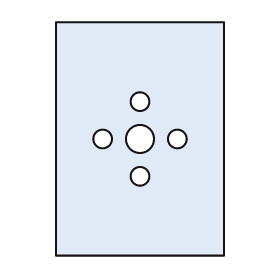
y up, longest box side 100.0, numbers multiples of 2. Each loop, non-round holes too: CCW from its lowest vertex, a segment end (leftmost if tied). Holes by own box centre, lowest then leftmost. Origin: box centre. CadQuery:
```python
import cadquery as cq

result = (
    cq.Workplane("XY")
    .moveTo(-36.0, -50.0)
    .lineTo(36.0, -50.0)
    .lineTo(36.0, 50.0)
    .lineTo(-36.0, 50.0)
    .close()
    .moveTo(0.0, -16.0)
    .circle(4.0)
    .moveTo(-16.0, 0.0)
    .circle(4.0)
    .moveTo(0.0, 0.0)
    .circle(6.0)
    .moveTo(16.0, 0.0)
    .circle(4.0)
    .moveTo(0.0, 16.0)
    .circle(4.0)
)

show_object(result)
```